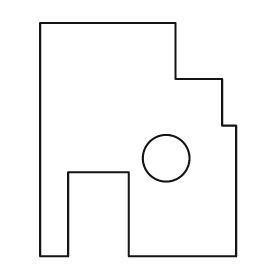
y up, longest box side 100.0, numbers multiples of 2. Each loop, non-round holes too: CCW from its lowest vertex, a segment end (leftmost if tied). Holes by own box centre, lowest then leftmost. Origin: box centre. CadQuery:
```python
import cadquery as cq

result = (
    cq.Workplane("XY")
    .moveTo(-42.0, -50.0)
    .lineTo(-30.0, -50.0)
    .lineTo(-30.0, -14.0)
    .lineTo(-4.0, -14.0)
    .lineTo(-4.0, -50.0)
    .lineTo(42.0, -50.0)
    .lineTo(42.0, 6.0)
    .lineTo(36.0, 6.0)
    .lineTo(36.0, 26.0)
    .lineTo(16.0, 26.0)
    .lineTo(16.0, 50.0)
    .lineTo(-42.0, 50.0)
    .close()
    .moveTo(12.0, -8.0)
    .circle(10.0)
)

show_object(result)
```